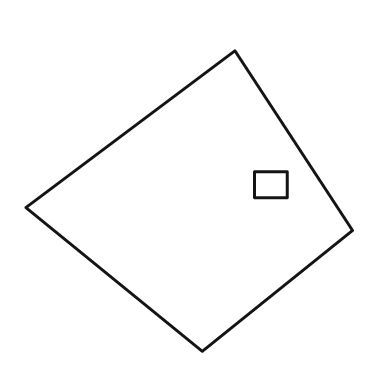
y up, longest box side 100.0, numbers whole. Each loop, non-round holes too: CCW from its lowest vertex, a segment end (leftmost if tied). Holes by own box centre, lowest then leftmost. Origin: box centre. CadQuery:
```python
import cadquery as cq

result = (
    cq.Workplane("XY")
    .moveTo(4.0, -46.0)
    .lineTo(50.0, -9.0)
    .lineTo(14.0, 46.0)
    .lineTo(-50.0, -2.0)
    .close()
    .moveTo(20.0, 1.0)
    .lineTo(30.0, 1.0)
    .lineTo(30.0, 9.0)
    .lineTo(20.0, 9.0)
    .close()
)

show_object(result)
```